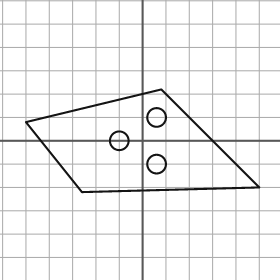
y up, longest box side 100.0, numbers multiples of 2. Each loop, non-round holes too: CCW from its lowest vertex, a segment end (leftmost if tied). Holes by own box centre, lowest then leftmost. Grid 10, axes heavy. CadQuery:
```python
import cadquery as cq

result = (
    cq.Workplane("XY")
    .moveTo(-26.0, -22.0)
    .lineTo(50.0, -20.0)
    .lineTo(8.0, 22.0)
    .lineTo(-50.0, 8.0)
    .close()
    .moveTo(6.0, -10.0)
    .circle(4.0)
    .moveTo(-10.0, 0.0)
    .circle(4.0)
    .moveTo(6.0, 10.0)
    .circle(4.0)
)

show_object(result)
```